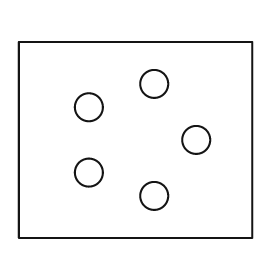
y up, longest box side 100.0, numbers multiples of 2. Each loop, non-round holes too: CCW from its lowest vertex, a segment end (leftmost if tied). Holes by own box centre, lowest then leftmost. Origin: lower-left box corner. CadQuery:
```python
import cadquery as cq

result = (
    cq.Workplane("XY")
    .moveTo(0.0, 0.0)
    .lineTo(100.0, 0.0)
    .lineTo(100.0, 84.0)
    .lineTo(0.0, 84.0)
    .close()
    .moveTo(58.0, 18.0)
    .circle(6.0)
    .moveTo(30.0, 28.0)
    .circle(6.0)
    .moveTo(76.0, 42.0)
    .circle(6.0)
    .moveTo(30.0, 56.0)
    .circle(6.0)
    .moveTo(58.0, 66.0)
    .circle(6.0)
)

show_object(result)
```